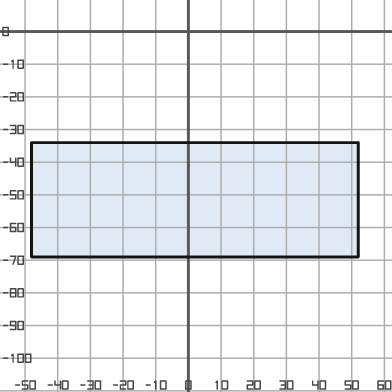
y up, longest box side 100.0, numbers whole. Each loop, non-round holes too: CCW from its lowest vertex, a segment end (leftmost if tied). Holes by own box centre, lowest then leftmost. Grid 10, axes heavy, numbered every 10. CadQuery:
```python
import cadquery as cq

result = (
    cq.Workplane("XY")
    .moveTo(-48.0, -69.0)
    .lineTo(52.0, -69.0)
    .lineTo(52.0, -34.0)
    .lineTo(-48.0, -34.0)
    .close()
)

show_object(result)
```